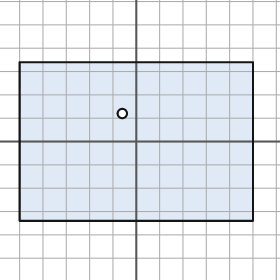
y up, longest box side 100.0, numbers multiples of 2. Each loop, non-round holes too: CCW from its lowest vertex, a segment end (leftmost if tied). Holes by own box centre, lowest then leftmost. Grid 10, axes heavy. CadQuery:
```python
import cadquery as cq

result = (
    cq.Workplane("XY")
    .moveTo(-50.0, -34.0)
    .lineTo(50.0, -34.0)
    .lineTo(50.0, 34.0)
    .lineTo(-50.0, 34.0)
    .close()
    .moveTo(-6.0, 12.0)
    .circle(2.0)
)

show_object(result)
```